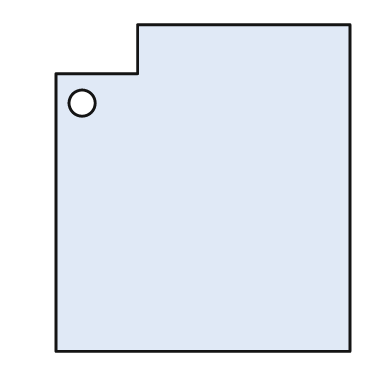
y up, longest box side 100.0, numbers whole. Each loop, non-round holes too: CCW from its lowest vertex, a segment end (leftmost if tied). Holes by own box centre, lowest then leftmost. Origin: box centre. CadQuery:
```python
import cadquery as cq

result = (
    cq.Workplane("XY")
    .moveTo(-45.0, -50.0)
    .lineTo(45.0, -50.0)
    .lineTo(45.0, 50.0)
    .lineTo(-20.0, 50.0)
    .lineTo(-20.0, 35.0)
    .lineTo(-45.0, 35.0)
    .close()
    .moveTo(-37.0, 26.0)
    .circle(4.0)
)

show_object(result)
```